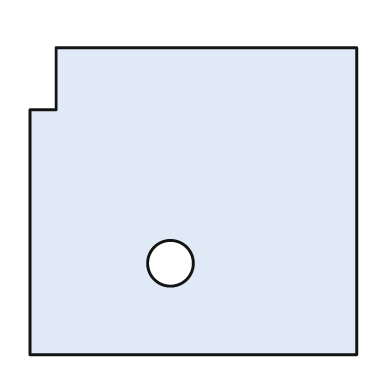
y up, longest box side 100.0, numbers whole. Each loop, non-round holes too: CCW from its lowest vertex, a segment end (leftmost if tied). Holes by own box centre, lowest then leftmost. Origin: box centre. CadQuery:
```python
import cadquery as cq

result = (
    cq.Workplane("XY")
    .moveTo(-50.0, -47.0)
    .lineTo(50.0, -47.0)
    .lineTo(50.0, 47.0)
    .lineTo(-42.0, 47.0)
    .lineTo(-42.0, 28.0)
    .lineTo(-50.0, 28.0)
    .close()
    .moveTo(-7.0, -19.0)
    .circle(7.0)
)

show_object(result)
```